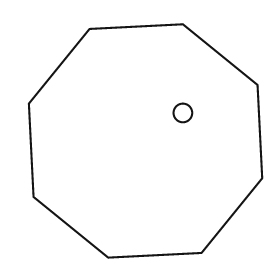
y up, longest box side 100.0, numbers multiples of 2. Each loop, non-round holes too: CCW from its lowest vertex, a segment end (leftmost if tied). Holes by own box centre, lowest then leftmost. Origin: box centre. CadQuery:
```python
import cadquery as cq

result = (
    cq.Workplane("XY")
    .moveTo(-16.0, -50.0)
    .lineTo(24.0, -48.0)
    .lineTo(50.0, -16.0)
    .lineTo(48.0, 24.0)
    .lineTo(16.0, 50.0)
    .lineTo(-24.0, 48.0)
    .lineTo(-50.0, 16.0)
    .lineTo(-48.0, -24.0)
    .close()
    .moveTo(16.0, 12.0)
    .circle(4.0)
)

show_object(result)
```